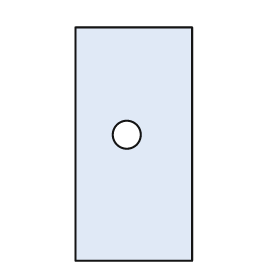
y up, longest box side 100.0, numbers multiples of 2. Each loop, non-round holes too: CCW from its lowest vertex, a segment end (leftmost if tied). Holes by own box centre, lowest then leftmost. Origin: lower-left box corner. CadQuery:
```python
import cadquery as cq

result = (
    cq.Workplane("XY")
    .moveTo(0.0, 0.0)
    .lineTo(50.0, 0.0)
    .lineTo(50.0, 100.0)
    .lineTo(0.0, 100.0)
    .close()
    .moveTo(22.0, 54.0)
    .circle(6.0)
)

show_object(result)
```